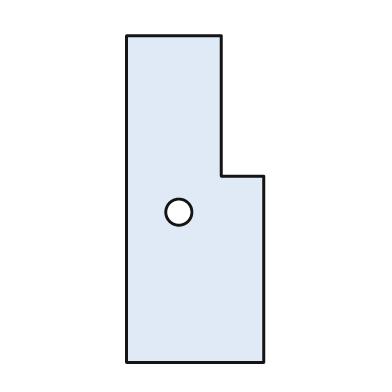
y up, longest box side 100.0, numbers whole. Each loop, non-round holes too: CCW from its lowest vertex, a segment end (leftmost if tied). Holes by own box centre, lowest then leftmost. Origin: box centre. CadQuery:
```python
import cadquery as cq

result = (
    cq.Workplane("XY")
    .moveTo(-21.0, -50.0)
    .lineTo(21.0, -50.0)
    .lineTo(21.0, 7.0)
    .lineTo(8.0, 7.0)
    .lineTo(8.0, 50.0)
    .lineTo(-21.0, 50.0)
    .close()
    .moveTo(-5.0, -4.0)
    .circle(4.0)
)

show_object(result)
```